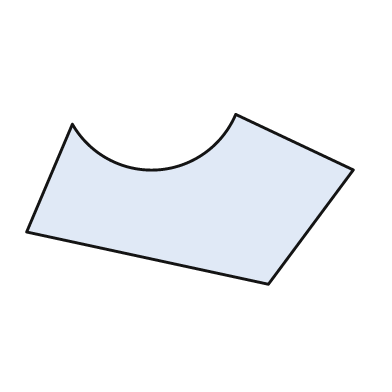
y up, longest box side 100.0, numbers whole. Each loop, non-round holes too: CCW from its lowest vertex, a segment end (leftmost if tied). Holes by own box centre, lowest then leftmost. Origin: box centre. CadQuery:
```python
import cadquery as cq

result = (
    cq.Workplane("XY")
    .moveTo(24.0, -26.0)
    .lineTo(50.0, 9.0)
    .lineTo(14.0, 26.0)
    .threePointArc((-10.0, 9.0), (-36.0, 23.0))
    .lineTo(-50.0, -10.0)
    .close()
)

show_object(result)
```